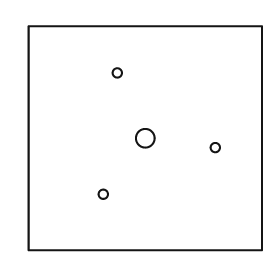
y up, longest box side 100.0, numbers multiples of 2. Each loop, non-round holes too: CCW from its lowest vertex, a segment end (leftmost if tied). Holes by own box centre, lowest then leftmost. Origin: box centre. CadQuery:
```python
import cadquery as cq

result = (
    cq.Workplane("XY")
    .moveTo(-50.0, -48.0)
    .lineTo(50.0, -48.0)
    .lineTo(50.0, 48.0)
    .lineTo(-50.0, 48.0)
    .close()
    .moveTo(-18.0, -24.0)
    .circle(2.0)
    .moveTo(30.0, -4.0)
    .circle(2.0)
    .moveTo(0.0, 0.0)
    .circle(4.0)
    .moveTo(-12.0, 28.0)
    .circle(2.0)
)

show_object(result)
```